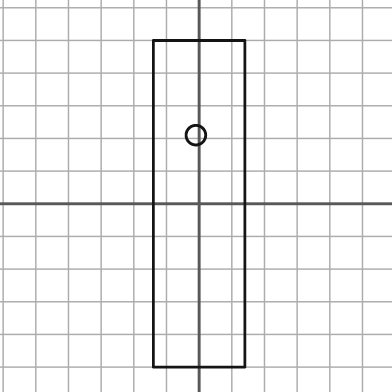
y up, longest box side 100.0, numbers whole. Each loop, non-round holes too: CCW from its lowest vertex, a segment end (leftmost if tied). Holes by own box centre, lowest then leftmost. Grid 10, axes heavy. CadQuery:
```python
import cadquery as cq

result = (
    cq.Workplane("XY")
    .moveTo(-14.0, -50.0)
    .lineTo(14.0, -50.0)
    .lineTo(14.0, 50.0)
    .lineTo(-14.0, 50.0)
    .close()
    .moveTo(-1.0, 21.0)
    .circle(3.0)
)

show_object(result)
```